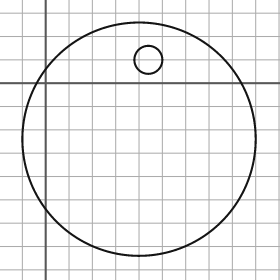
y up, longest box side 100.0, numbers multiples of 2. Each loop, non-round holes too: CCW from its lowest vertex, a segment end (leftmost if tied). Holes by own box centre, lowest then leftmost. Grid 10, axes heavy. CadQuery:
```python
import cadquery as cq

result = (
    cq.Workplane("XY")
    .moveTo(40.0, -24.0)
    .circle(50.0)
    .moveTo(44.0, 10.0)
    .circle(6.0)
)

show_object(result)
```